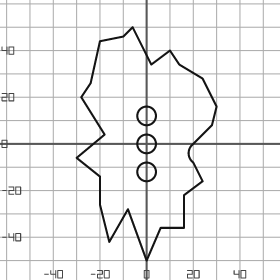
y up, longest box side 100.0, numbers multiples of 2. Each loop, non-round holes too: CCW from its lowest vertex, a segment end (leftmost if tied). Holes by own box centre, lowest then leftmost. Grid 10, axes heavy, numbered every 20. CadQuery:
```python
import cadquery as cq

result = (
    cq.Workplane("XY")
    .moveTo(0.0, -50.0)
    .lineTo(6.0, -36.0)
    .lineTo(16.0, -36.0)
    .lineTo(16.0, -22.0)
    .lineTo(24.0, -16.0)
    .lineTo(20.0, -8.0)
    .threePointArc((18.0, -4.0), (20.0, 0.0))
    .lineTo(28.0, 8.0)
    .lineTo(30.0, 16.0)
    .lineTo(24.0, 28.0)
    .lineTo(14.0, 34.0)
    .lineTo(10.0, 40.0)
    .lineTo(2.0, 34.0)
    .lineTo(-6.0, 50.0)
    .lineTo(-10.0, 46.0)
    .lineTo(-20.0, 44.0)
    .lineTo(-24.0, 26.0)
    .lineTo(-28.0, 20.0)
    .lineTo(-18.0, 4.0)
    .lineTo(-30.0, -6.0)
    .lineTo(-20.0, -14.0)
    .lineTo(-20.0, -26.0)
    .lineTo(-16.0, -42.0)
    .lineTo(-8.0, -28.0)
    .close()
    .moveTo(0.0, -12.0)
    .circle(4.0)
    .moveTo(0.0, 0.0)
    .circle(4.0)
    .moveTo(0.0, 12.0)
    .circle(4.0)
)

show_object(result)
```